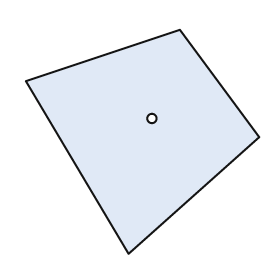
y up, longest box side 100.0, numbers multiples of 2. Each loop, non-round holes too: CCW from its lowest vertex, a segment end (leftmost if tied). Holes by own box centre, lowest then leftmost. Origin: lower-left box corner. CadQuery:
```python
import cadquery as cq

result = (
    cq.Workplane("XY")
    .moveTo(44.0, 0.0)
    .lineTo(100.0, 50.0)
    .lineTo(66.0, 96.0)
    .lineTo(0.0, 74.0)
    .close()
    .moveTo(54.0, 58.0)
    .circle(2.0)
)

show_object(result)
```